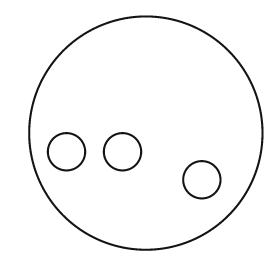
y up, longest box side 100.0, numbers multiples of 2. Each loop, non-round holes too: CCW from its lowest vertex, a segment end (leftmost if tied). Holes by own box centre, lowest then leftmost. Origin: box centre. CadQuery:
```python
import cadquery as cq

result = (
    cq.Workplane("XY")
    .moveTo(0.0, 0.0)
    .circle(50.0)
    .moveTo(24.0, -20.0)
    .circle(8.0)
    .moveTo(-34.0, -8.0)
    .circle(8.0)
    .moveTo(-10.0, -8.0)
    .circle(8.0)
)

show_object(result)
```